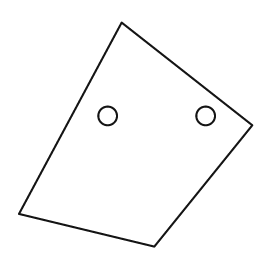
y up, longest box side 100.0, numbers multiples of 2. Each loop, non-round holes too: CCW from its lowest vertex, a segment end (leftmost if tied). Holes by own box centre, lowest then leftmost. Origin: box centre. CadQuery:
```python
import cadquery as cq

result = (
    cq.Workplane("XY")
    .moveTo(8.0, -48.0)
    .lineTo(50.0, 4.0)
    .lineTo(-6.0, 48.0)
    .lineTo(-50.0, -34.0)
    .close()
    .moveTo(-12.0, 8.0)
    .circle(4.0)
    .moveTo(30.0, 8.0)
    .circle(4.0)
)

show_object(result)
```